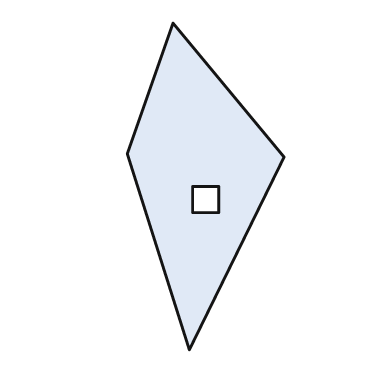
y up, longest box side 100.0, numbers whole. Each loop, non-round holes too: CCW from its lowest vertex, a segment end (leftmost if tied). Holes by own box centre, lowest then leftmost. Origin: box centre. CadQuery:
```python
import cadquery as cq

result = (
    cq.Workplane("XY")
    .moveTo(-5.0, -50.0)
    .lineTo(24.0, 9.0)
    .lineTo(-10.0, 50.0)
    .lineTo(-24.0, 10.0)
    .close()
    .moveTo(-4.0, -8.0)
    .lineTo(4.0, -8.0)
    .lineTo(4.0, 0.0)
    .lineTo(-4.0, 0.0)
    .close()
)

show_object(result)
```